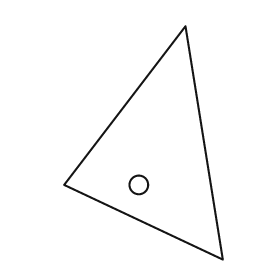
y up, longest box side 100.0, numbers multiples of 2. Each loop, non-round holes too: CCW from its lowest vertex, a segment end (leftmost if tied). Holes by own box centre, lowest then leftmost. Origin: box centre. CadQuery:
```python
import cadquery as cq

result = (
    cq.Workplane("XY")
    .moveTo(34.0, -50.0)
    .lineTo(18.0, 50.0)
    .lineTo(-34.0, -18.0)
    .close()
    .moveTo(-2.0, -18.0)
    .circle(4.0)
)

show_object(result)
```